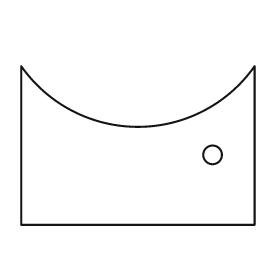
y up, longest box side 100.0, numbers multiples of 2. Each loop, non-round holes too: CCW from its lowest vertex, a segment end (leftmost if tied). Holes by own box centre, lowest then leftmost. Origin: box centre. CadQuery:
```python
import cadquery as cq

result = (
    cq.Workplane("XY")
    .moveTo(-50.0, -34.0)
    .lineTo(50.0, -34.0)
    .lineTo(50.0, 34.0)
    .threePointArc((0.0, 8.0), (-50.0, 34.0))
    .close()
    .moveTo(32.0, -4.0)
    .circle(4.0)
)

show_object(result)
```